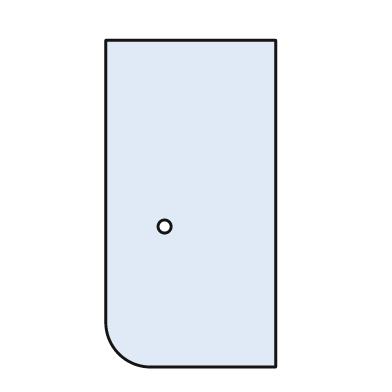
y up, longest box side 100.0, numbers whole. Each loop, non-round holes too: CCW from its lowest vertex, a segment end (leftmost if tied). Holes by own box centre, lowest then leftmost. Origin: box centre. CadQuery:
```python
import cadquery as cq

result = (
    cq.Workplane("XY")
    .moveTo(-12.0, -50.0)
    .lineTo(26.0, -50.0)
    .lineTo(26.0, 50.0)
    .lineTo(-26.0, 50.0)
    .lineTo(-26.0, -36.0)
    .threePointArc((-22.0, -46.0), (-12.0, -50.0))
    .close()
    .moveTo(-8.0, -7.0)
    .circle(2.0)
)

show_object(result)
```